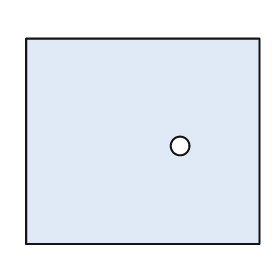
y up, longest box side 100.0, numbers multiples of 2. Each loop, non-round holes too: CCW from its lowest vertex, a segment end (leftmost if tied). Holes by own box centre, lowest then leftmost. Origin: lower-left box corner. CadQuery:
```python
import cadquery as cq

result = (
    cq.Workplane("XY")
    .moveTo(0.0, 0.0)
    .lineTo(100.0, 0.0)
    .lineTo(100.0, 88.0)
    .lineTo(0.0, 88.0)
    .close()
    .moveTo(66.0, 42.0)
    .circle(4.0)
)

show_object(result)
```